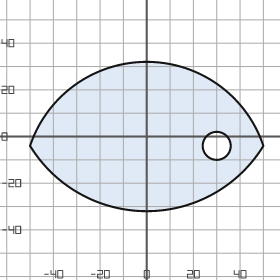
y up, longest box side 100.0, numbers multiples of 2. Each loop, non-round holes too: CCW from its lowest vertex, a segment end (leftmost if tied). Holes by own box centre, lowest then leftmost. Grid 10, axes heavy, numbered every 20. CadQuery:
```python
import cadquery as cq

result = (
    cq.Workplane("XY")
    .moveTo(-50.0, -4.0)
    .threePointArc((0.0, -32.0), (50.0, -4.0))
    .threePointArc((0.0, 32.0), (-50.0, -4.0))
    .close()
    .moveTo(30.0, -4.0)
    .circle(6.0)
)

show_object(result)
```